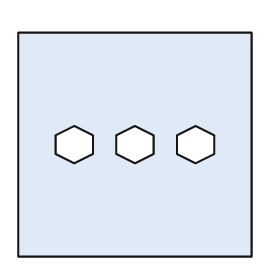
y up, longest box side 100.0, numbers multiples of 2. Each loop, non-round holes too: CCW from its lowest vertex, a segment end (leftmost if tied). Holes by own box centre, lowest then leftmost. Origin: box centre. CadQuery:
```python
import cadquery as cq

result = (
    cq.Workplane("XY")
    .moveTo(-50.0, -48.0)
    .lineTo(50.0, -48.0)
    .lineTo(50.0, 48.0)
    .lineTo(-50.0, 48.0)
    .close()
    .moveTo(-26.0, -8.0)
    .lineTo(-18.0, -4.0)
    .lineTo(-18.0, 4.0)
    .lineTo(-26.0, 8.0)
    .lineTo(-34.0, 4.0)
    .lineTo(-34.0, -4.0)
    .close()
    .moveTo(0.0, -8.0)
    .lineTo(8.0, -4.0)
    .lineTo(8.0, 4.0)
    .lineTo(0.0, 8.0)
    .lineTo(-8.0, 4.0)
    .lineTo(-8.0, -4.0)
    .close()
    .moveTo(26.0, -8.0)
    .lineTo(34.0, -4.0)
    .lineTo(34.0, 4.0)
    .lineTo(26.0, 8.0)
    .lineTo(18.0, 4.0)
    .lineTo(18.0, -4.0)
    .close()
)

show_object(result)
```